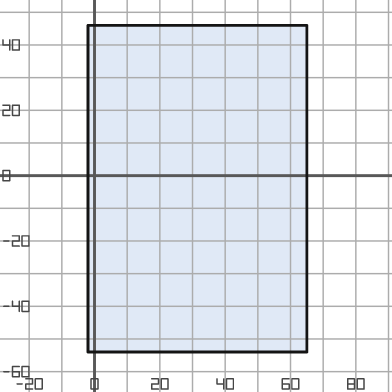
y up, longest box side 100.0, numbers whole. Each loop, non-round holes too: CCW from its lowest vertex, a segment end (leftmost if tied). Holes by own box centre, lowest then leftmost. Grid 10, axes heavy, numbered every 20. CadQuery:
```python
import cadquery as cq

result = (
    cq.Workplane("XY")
    .moveTo(-2.0, -54.0)
    .lineTo(65.0, -54.0)
    .lineTo(65.0, 46.0)
    .lineTo(-2.0, 46.0)
    .close()
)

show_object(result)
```